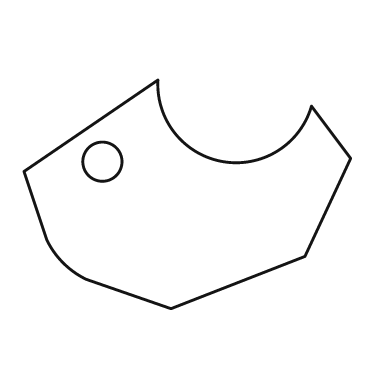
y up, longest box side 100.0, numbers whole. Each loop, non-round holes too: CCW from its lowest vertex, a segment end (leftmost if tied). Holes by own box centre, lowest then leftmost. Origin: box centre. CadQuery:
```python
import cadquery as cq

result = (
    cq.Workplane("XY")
    .moveTo(-5.0, -35.0)
    .lineTo(36.0, -19.0)
    .lineTo(50.0, 11.0)
    .lineTo(38.0, 27.0)
    .threePointArc((11.0, 10.0), (-9.0, 35.0))
    .lineTo(-50.0, 7.0)
    .lineTo(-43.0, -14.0)
    .threePointArc((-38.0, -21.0), (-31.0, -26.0))
    .close()
    .moveTo(-26.0, 10.0)
    .circle(6.0)
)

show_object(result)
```